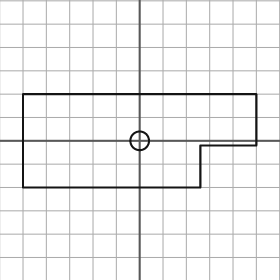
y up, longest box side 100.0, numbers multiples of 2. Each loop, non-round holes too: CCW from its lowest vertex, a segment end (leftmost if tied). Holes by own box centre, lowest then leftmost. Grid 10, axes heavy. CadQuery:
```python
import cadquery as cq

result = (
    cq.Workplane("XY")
    .moveTo(-50.0, -20.0)
    .lineTo(26.0, -20.0)
    .lineTo(26.0, -2.0)
    .lineTo(50.0, -2.0)
    .lineTo(50.0, 20.0)
    .lineTo(-50.0, 20.0)
    .close()
    .moveTo(0.0, 0.0)
    .circle(4.0)
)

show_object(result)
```